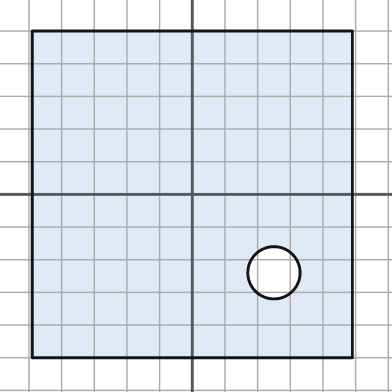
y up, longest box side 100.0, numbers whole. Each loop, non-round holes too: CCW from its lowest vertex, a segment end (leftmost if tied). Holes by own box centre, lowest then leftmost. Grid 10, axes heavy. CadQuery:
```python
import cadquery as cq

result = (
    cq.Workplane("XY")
    .moveTo(-49.0, -50.0)
    .lineTo(49.0, -50.0)
    .lineTo(49.0, 50.0)
    .lineTo(-49.0, 50.0)
    .close()
    .moveTo(25.0, -24.0)
    .circle(8.0)
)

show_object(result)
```